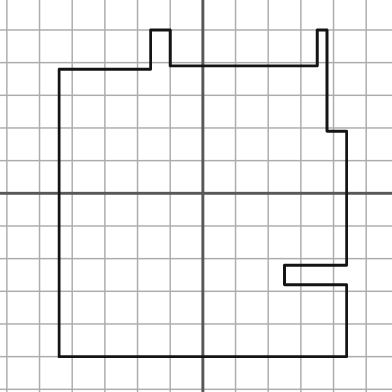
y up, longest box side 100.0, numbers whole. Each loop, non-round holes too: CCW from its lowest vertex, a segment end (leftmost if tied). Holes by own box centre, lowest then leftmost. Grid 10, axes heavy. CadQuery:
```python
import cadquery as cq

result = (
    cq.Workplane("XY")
    .moveTo(-44.0, -50.0)
    .lineTo(44.0, -50.0)
    .lineTo(44.0, -28.0)
    .lineTo(25.0, -28.0)
    .lineTo(25.0, -22.0)
    .lineTo(44.0, -22.0)
    .lineTo(44.0, 19.0)
    .lineTo(38.0, 19.0)
    .lineTo(38.0, 50.0)
    .lineTo(35.0, 50.0)
    .lineTo(35.0, 39.0)
    .lineTo(-10.0, 39.0)
    .lineTo(-10.0, 50.0)
    .lineTo(-16.0, 50.0)
    .lineTo(-16.0, 38.0)
    .lineTo(-44.0, 38.0)
    .close()
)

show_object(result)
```